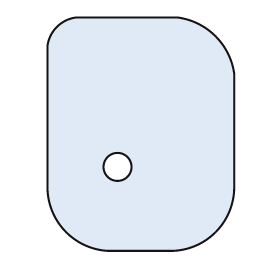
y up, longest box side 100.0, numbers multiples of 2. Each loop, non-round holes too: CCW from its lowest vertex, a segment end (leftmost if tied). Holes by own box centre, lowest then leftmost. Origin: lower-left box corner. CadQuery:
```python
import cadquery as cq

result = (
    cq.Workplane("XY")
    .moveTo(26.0, 0.0)
    .lineTo(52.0, 0.0)
    .threePointArc((72.0, 8.0), (80.0, 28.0))
    .lineTo(80.0, 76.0)
    .threePointArc((72.0, 92.0), (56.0, 100.0))
    .lineTo(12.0, 100.0)
    .threePointArc((4.0, 96.0), (0.0, 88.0))
    .lineTo(0.0, 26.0)
    .threePointArc((8.0, 8.0), (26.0, 0.0))
    .close()
    .moveTo(30.0, 36.0)
    .circle(6.0)
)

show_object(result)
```